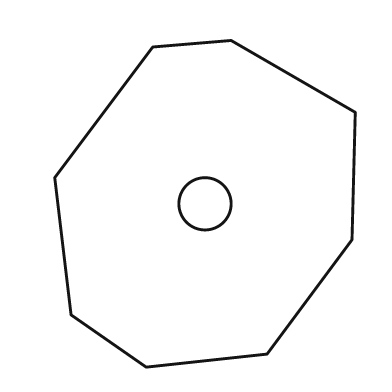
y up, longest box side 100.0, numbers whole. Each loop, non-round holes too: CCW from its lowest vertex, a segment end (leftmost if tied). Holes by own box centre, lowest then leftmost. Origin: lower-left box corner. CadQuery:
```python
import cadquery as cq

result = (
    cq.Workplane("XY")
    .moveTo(28.0, 0.0)
    .lineTo(65.0, 4.0)
    .lineTo(91.0, 39.0)
    .lineTo(92.0, 78.0)
    .lineTo(54.0, 100.0)
    .lineTo(30.0, 98.0)
    .lineTo(0.0, 58.0)
    .lineTo(5.0, 16.0)
    .close()
    .moveTo(46.0, 50.0)
    .circle(8.0)
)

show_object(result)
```